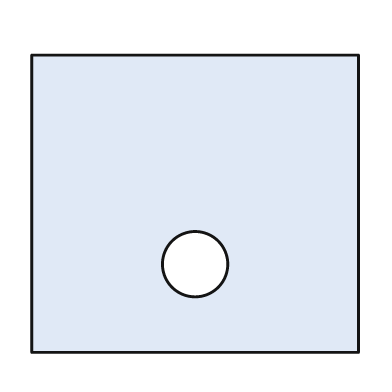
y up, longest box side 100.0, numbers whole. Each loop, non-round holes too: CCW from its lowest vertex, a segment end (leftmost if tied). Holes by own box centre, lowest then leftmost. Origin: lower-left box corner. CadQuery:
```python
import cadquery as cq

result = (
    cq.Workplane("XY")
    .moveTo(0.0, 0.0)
    .lineTo(100.0, 0.0)
    .lineTo(100.0, 91.0)
    .lineTo(0.0, 91.0)
    .close()
    .moveTo(50.0, 27.0)
    .circle(10.0)
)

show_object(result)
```